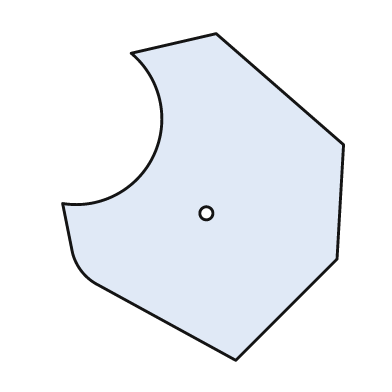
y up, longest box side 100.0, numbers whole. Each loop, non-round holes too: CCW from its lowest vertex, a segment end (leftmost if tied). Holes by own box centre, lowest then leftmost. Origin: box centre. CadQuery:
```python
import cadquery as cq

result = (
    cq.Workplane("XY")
    .moveTo(10.0, -50.0)
    .lineTo(41.0, -19.0)
    .lineTo(43.0, 16.0)
    .lineTo(4.0, 50.0)
    .lineTo(-22.0, 44.0)
    .threePointArc((-15.0, 13.0), (-43.0, -2.0))
    .lineTo(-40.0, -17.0)
    .threePointArc((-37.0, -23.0), (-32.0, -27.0))
    .close()
    .moveTo(1.0, -5.0)
    .circle(2.0)
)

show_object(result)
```